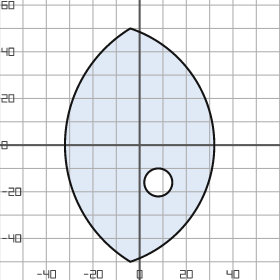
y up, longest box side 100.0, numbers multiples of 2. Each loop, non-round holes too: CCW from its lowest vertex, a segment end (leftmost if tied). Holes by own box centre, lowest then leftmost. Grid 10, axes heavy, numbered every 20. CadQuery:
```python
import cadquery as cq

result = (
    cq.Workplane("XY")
    .moveTo(-4.0, -50.0)
    .threePointArc((32.0, 0.0), (-4.0, 50.0))
    .threePointArc((-32.0, 0.0), (-4.0, -50.0))
    .close()
    .moveTo(8.0, -16.0)
    .circle(6.0)
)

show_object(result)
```